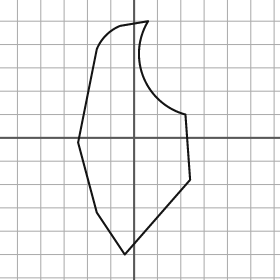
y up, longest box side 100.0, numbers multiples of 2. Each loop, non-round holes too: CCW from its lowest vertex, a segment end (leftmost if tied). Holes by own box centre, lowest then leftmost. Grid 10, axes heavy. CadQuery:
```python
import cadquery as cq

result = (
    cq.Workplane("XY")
    .moveTo(-4.0, -50.0)
    .lineTo(24.0, -18.0)
    .lineTo(22.0, 10.0)
    .threePointArc((4.0, 26.0), (6.0, 50.0))
    .lineTo(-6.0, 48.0)
    .threePointArc((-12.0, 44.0), (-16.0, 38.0))
    .lineTo(-24.0, -2.0)
    .lineTo(-16.0, -32.0)
    .close()
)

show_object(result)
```